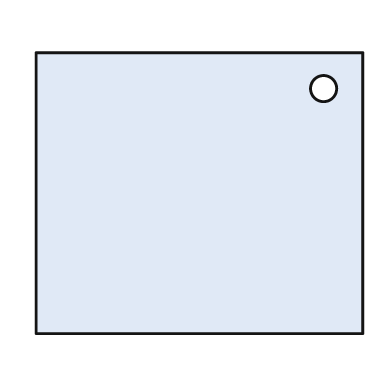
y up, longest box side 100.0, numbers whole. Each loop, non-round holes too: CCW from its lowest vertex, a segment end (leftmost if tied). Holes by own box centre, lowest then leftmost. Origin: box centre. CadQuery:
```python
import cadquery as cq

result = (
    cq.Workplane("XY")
    .moveTo(-50.0, -43.0)
    .lineTo(50.0, -43.0)
    .lineTo(50.0, 43.0)
    .lineTo(-50.0, 43.0)
    .close()
    .moveTo(38.0, 32.0)
    .circle(4.0)
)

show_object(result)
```